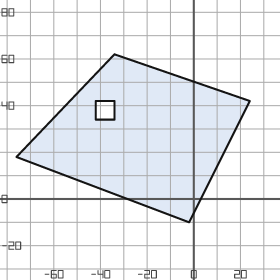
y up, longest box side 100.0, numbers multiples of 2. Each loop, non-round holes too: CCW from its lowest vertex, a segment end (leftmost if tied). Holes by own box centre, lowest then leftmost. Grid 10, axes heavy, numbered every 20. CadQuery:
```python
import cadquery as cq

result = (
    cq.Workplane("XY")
    .moveTo(-2.0, -10.0)
    .lineTo(24.0, 42.0)
    .lineTo(-34.0, 62.0)
    .lineTo(-76.0, 18.0)
    .close()
    .moveTo(-42.0, 34.0)
    .lineTo(-34.0, 34.0)
    .lineTo(-34.0, 42.0)
    .lineTo(-42.0, 42.0)
    .close()
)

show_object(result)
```